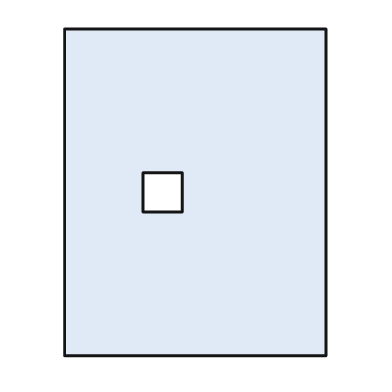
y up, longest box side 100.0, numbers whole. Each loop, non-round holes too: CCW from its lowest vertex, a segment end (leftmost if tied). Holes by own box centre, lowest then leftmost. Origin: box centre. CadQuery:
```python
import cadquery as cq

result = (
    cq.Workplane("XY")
    .moveTo(-40.0, -50.0)
    .lineTo(40.0, -50.0)
    .lineTo(40.0, 50.0)
    .lineTo(-40.0, 50.0)
    .close()
    .moveTo(-16.0, -6.0)
    .lineTo(-4.0, -6.0)
    .lineTo(-4.0, 6.0)
    .lineTo(-16.0, 6.0)
    .close()
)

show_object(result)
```